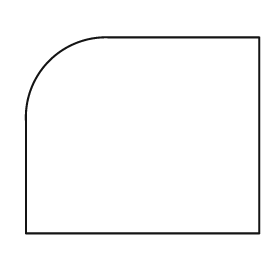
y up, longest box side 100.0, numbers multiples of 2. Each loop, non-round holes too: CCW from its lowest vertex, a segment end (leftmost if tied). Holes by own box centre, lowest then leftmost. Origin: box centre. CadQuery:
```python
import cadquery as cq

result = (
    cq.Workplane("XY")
    .moveTo(-50.0, -42.0)
    .lineTo(50.0, -42.0)
    .lineTo(50.0, 42.0)
    .lineTo(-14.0, 42.0)
    .threePointArc((-40.0, 32.0), (-50.0, 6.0))
    .close()
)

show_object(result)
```